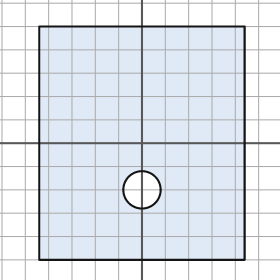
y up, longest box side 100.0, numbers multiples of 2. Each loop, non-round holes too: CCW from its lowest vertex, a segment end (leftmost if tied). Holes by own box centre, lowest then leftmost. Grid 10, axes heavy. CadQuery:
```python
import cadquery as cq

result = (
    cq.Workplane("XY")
    .moveTo(-44.0, -50.0)
    .lineTo(44.0, -50.0)
    .lineTo(44.0, 50.0)
    .lineTo(-44.0, 50.0)
    .close()
    .moveTo(0.0, -20.0)
    .circle(8.0)
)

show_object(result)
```